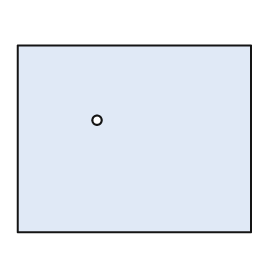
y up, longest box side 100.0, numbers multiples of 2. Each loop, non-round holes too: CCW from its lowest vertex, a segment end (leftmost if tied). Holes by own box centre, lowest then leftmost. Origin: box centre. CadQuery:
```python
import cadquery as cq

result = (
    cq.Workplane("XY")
    .moveTo(-50.0, -40.0)
    .lineTo(50.0, -40.0)
    .lineTo(50.0, 40.0)
    .lineTo(-50.0, 40.0)
    .close()
    .moveTo(-16.0, 8.0)
    .circle(2.0)
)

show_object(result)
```